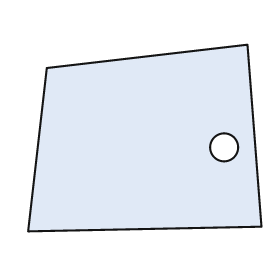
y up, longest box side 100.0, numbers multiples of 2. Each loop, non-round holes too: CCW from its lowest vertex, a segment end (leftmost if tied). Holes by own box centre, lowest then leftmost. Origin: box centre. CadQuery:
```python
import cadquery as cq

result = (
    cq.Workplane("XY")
    .moveTo(-50.0, -40.0)
    .lineTo(50.0, -38.0)
    .lineTo(44.0, 40.0)
    .lineTo(-42.0, 30.0)
    .close()
    .moveTo(34.0, -4.0)
    .circle(6.0)
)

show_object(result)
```